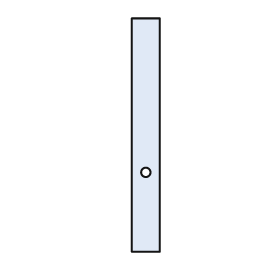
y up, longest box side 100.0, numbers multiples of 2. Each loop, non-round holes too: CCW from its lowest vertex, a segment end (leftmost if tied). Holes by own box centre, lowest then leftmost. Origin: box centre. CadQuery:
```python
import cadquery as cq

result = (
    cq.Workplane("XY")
    .moveTo(-6.0, -50.0)
    .lineTo(6.0, -50.0)
    .lineTo(6.0, 50.0)
    .lineTo(-6.0, 50.0)
    .close()
    .moveTo(0.0, -16.0)
    .circle(2.0)
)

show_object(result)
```